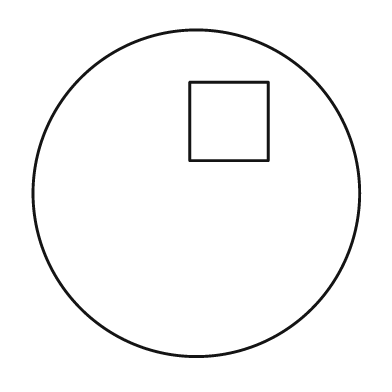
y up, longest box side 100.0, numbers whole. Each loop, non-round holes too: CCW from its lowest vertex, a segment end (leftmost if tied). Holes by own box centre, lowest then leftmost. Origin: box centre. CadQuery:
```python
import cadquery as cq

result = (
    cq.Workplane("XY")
    .moveTo(0.0, 0.0)
    .circle(50.0)
    .moveTo(-2.0, 10.0)
    .lineTo(22.0, 10.0)
    .lineTo(22.0, 34.0)
    .lineTo(-2.0, 34.0)
    .close()
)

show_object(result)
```